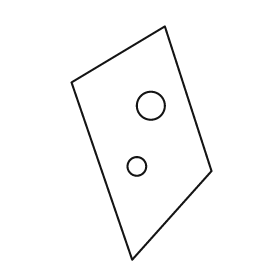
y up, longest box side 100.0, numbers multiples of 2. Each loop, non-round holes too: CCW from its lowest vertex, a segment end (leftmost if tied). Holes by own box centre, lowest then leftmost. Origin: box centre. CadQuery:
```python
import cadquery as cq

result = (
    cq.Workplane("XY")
    .moveTo(-4.0, -50.0)
    .lineTo(30.0, -12.0)
    .lineTo(10.0, 50.0)
    .lineTo(-30.0, 26.0)
    .close()
    .moveTo(-2.0, -10.0)
    .circle(4.0)
    .moveTo(4.0, 16.0)
    .circle(6.0)
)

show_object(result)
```